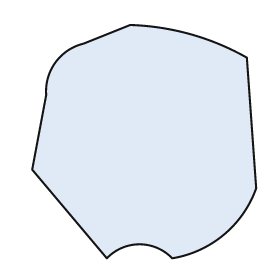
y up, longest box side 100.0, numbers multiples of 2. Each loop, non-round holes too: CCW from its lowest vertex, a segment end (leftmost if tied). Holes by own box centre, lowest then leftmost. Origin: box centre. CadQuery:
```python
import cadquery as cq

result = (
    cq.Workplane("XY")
    .moveTo(-16.0, -50.0)
    .threePointArc((-2.0, -44.0), (12.0, -50.0))
    .threePointArc((34.0, -40.0), (48.0, -20.0))
    .lineTo(44.0, 36.0)
    .threePointArc((20.0, 46.0), (-6.0, 50.0))
    .lineTo(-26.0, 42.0)
    .threePointArc((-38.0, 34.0), (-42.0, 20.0))
    .lineTo(-48.0, -12.0)
    .close()
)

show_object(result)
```